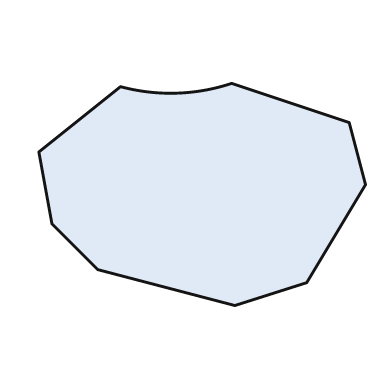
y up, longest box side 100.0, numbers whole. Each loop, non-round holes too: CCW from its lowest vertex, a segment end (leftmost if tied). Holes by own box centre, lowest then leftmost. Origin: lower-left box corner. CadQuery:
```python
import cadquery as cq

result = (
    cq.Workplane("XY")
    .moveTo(60.0, 0.0)
    .lineTo(82.0, 7.0)
    .lineTo(100.0, 37.0)
    .lineTo(95.0, 56.0)
    .lineTo(59.0, 68.0)
    .threePointArc((42.0, 65.0), (25.0, 67.0))
    .lineTo(0.0, 47.0)
    .lineTo(4.0, 25.0)
    .lineTo(18.0, 11.0)
    .close()
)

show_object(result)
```